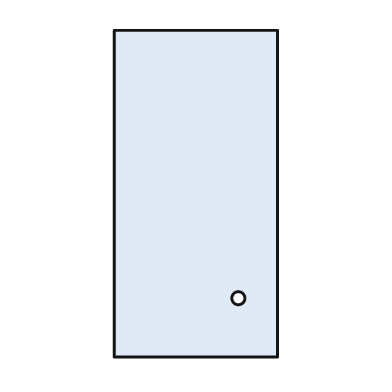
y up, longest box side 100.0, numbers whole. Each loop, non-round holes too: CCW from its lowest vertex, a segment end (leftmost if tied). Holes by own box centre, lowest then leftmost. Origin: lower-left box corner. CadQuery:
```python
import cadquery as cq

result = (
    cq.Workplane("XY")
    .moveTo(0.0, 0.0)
    .lineTo(50.0, 0.0)
    .lineTo(50.0, 100.0)
    .lineTo(0.0, 100.0)
    .close()
    .moveTo(38.0, 18.0)
    .circle(2.0)
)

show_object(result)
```